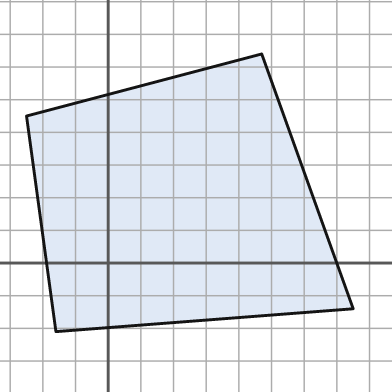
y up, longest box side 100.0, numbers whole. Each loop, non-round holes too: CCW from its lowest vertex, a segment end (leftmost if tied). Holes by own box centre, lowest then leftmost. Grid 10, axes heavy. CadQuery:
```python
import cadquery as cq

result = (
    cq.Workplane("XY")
    .moveTo(-16.0, -21.0)
    .lineTo(75.0, -14.0)
    .lineTo(47.0, 64.0)
    .lineTo(-25.0, 45.0)
    .close()
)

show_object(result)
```